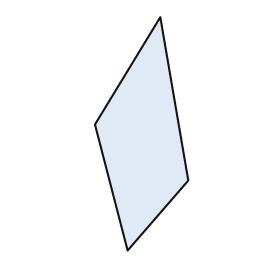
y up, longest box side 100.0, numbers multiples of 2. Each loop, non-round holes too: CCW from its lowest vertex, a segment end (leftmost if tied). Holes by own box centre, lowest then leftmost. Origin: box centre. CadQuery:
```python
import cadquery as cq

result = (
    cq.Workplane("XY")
    .moveTo(-6.0, -50.0)
    .lineTo(20.0, -20.0)
    .lineTo(8.0, 50.0)
    .lineTo(-20.0, 4.0)
    .close()
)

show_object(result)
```